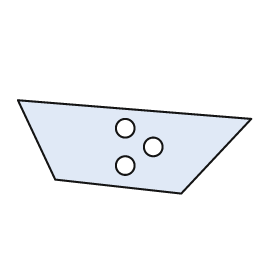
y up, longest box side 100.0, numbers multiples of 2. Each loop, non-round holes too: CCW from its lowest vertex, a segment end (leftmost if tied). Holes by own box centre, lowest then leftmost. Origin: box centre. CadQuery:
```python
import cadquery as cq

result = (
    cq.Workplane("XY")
    .moveTo(20.0, -20.0)
    .lineTo(50.0, 12.0)
    .lineTo(-50.0, 20.0)
    .lineTo(-34.0, -14.0)
    .close()
    .moveTo(-4.0, -8.0)
    .circle(4.0)
    .moveTo(8.0, 0.0)
    .circle(4.0)
    .moveTo(-4.0, 8.0)
    .circle(4.0)
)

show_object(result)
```